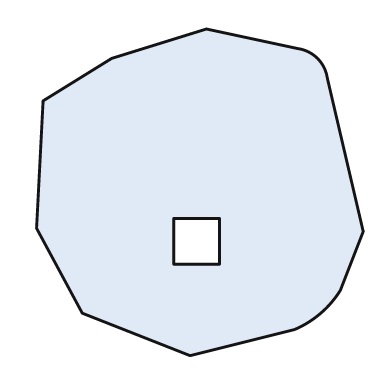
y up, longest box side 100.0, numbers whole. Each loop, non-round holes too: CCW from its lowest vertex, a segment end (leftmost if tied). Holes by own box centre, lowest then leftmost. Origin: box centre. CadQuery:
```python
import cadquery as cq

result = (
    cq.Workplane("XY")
    .moveTo(-3.0, -50.0)
    .lineTo(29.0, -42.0)
    .threePointArc((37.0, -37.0), (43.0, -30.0))
    .lineTo(50.0, -12.0)
    .lineTo(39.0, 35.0)
    .threePointArc((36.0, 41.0), (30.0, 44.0))
    .lineTo(2.0, 50.0)
    .lineTo(-27.0, 41.0)
    .lineTo(-48.0, 28.0)
    .lineTo(-50.0, -11.0)
    .lineTo(-36.0, -37.0)
    .close()
    .moveTo(-8.0, -22.0)
    .lineTo(6.0, -22.0)
    .lineTo(6.0, -8.0)
    .lineTo(-8.0, -8.0)
    .close()
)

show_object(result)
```